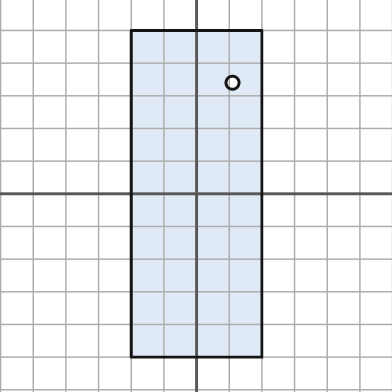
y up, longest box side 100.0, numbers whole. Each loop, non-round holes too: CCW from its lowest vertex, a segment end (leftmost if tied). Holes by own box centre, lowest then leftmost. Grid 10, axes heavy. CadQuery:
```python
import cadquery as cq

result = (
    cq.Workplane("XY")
    .moveTo(-20.0, -50.0)
    .lineTo(20.0, -50.0)
    .lineTo(20.0, 50.0)
    .lineTo(-20.0, 50.0)
    .close()
    .moveTo(11.0, 34.0)
    .circle(2.0)
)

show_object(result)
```